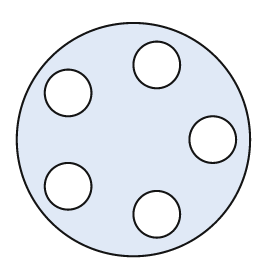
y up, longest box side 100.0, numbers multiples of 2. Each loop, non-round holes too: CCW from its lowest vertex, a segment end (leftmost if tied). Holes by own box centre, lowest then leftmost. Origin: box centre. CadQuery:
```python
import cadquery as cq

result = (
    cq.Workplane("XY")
    .moveTo(0.0, 0.0)
    .circle(50.0)
    .moveTo(10.0, -32.0)
    .circle(10.0)
    .moveTo(-28.0, -20.0)
    .circle(10.0)
    .moveTo(34.0, 0.0)
    .circle(10.0)
    .moveTo(-28.0, 20.0)
    .circle(10.0)
    .moveTo(10.0, 32.0)
    .circle(10.0)
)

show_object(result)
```